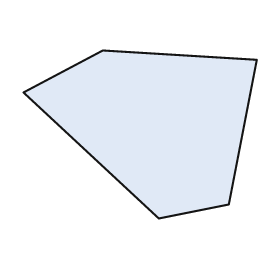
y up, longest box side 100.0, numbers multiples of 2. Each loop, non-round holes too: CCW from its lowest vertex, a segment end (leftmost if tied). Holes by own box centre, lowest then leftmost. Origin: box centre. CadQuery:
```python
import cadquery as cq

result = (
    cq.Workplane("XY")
    .moveTo(8.0, -36.0)
    .lineTo(38.0, -30.0)
    .lineTo(50.0, 32.0)
    .lineTo(-16.0, 36.0)
    .lineTo(-50.0, 18.0)
    .close()
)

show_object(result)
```